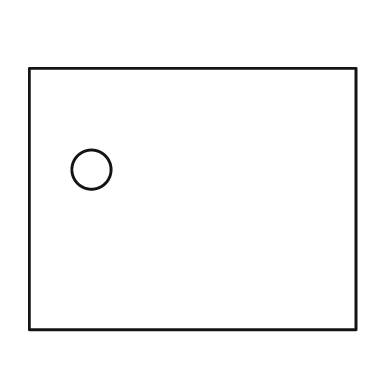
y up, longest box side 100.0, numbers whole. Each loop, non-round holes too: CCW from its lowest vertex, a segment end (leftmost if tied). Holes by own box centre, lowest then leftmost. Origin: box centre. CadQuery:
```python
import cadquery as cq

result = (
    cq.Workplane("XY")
    .moveTo(-50.0, -40.0)
    .lineTo(50.0, -40.0)
    .lineTo(50.0, 40.0)
    .lineTo(-50.0, 40.0)
    .close()
    .moveTo(-31.0, 9.0)
    .circle(6.0)
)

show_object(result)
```